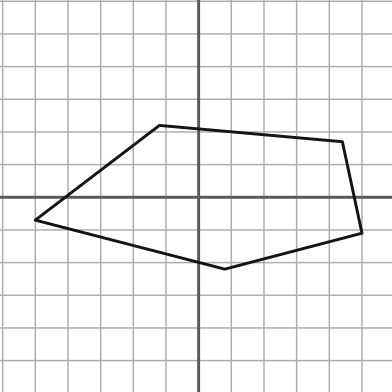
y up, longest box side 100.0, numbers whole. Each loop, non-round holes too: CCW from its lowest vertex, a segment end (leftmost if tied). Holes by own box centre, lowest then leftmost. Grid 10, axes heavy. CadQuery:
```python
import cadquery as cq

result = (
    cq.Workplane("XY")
    .moveTo(8.0, -22.0)
    .lineTo(50.0, -11.0)
    .lineTo(44.0, 17.0)
    .lineTo(-12.0, 22.0)
    .lineTo(-50.0, -7.0)
    .close()
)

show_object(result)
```